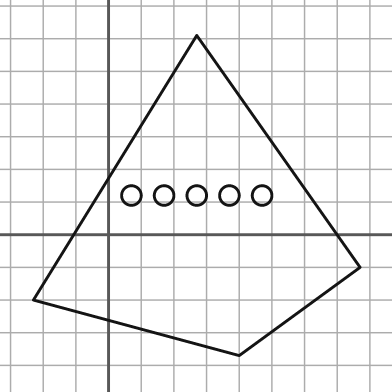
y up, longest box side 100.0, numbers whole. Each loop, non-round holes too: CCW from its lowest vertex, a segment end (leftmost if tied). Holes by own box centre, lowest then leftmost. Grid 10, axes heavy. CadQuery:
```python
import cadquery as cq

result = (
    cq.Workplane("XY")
    .moveTo(40.0, -37.0)
    .lineTo(77.0, -10.0)
    .lineTo(27.0, 61.0)
    .lineTo(-23.0, -20.0)
    .close()
    .moveTo(7.0, 12.0)
    .circle(3.0)
    .moveTo(17.0, 12.0)
    .circle(3.0)
    .moveTo(27.0, 12.0)
    .circle(3.0)
    .moveTo(37.0, 12.0)
    .circle(3.0)
    .moveTo(47.0, 12.0)
    .circle(3.0)
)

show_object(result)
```